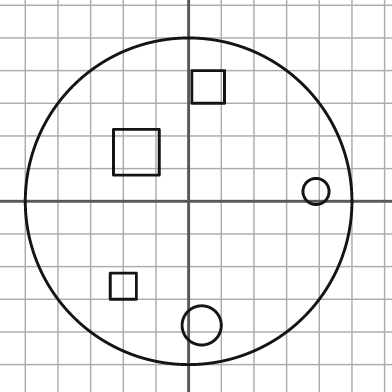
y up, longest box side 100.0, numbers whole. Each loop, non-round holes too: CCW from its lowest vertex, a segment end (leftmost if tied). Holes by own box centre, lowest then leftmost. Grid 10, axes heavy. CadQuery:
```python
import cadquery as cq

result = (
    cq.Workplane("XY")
    .moveTo(0.0, 0.0)
    .circle(50.0)
    .moveTo(4.0, -38.0)
    .circle(6.0)
    .moveTo(-24.0, -30.0)
    .lineTo(-16.0, -30.0)
    .lineTo(-16.0, -22.0)
    .lineTo(-24.0, -22.0)
    .close()
    .moveTo(39.0, 3.0)
    .circle(4.0)
    .moveTo(-23.0, 8.0)
    .lineTo(-9.0, 8.0)
    .lineTo(-9.0, 22.0)
    .lineTo(-23.0, 22.0)
    .close()
    .moveTo(1.0, 30.0)
    .lineTo(11.0, 30.0)
    .lineTo(11.0, 40.0)
    .lineTo(1.0, 40.0)
    .close()
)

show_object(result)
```